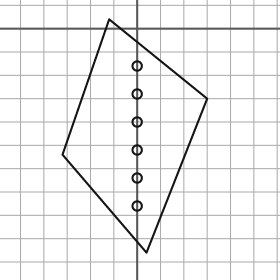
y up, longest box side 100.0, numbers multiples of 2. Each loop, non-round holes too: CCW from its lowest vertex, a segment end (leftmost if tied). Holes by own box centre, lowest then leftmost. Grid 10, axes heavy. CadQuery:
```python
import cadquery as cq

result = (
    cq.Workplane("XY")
    .moveTo(4.0, -96.0)
    .lineTo(30.0, -30.0)
    .lineTo(-12.0, 4.0)
    .lineTo(-32.0, -54.0)
    .close()
    .moveTo(0.0, -76.0)
    .circle(2.0)
    .moveTo(0.0, -64.0)
    .circle(2.0)
    .moveTo(0.0, -52.0)
    .circle(2.0)
    .moveTo(0.0, -40.0)
    .circle(2.0)
    .moveTo(0.0, -28.0)
    .circle(2.0)
    .moveTo(0.0, -16.0)
    .circle(2.0)
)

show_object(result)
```